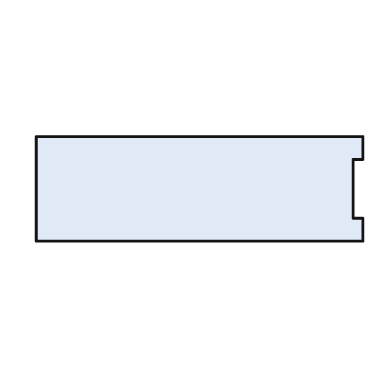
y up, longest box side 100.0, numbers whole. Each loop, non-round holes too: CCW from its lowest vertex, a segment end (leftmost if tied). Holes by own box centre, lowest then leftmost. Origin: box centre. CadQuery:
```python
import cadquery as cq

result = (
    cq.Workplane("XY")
    .moveTo(-50.0, -16.0)
    .lineTo(50.0, -16.0)
    .lineTo(50.0, -9.0)
    .lineTo(47.0, -9.0)
    .lineTo(47.0, 9.0)
    .lineTo(50.0, 9.0)
    .lineTo(50.0, 16.0)
    .lineTo(-50.0, 16.0)
    .close()
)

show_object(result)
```